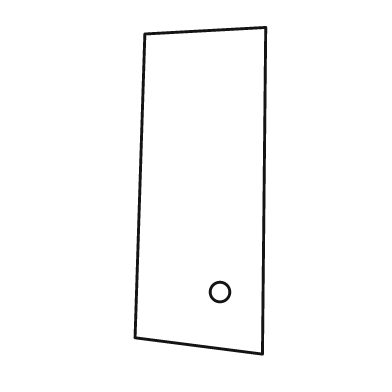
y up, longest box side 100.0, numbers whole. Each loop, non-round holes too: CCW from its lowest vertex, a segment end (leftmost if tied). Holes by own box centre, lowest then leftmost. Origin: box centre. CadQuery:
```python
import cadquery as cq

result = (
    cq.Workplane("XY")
    .moveTo(19.0, -50.0)
    .lineTo(20.0, 50.0)
    .lineTo(-17.0, 48.0)
    .lineTo(-20.0, -45.0)
    .close()
    .moveTo(6.0, -31.0)
    .circle(3.0)
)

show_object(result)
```